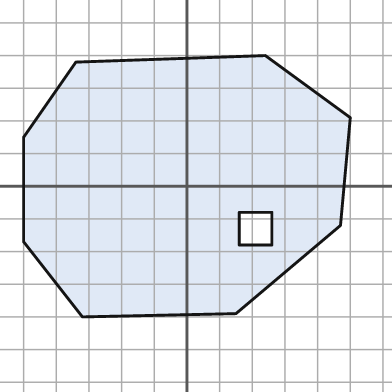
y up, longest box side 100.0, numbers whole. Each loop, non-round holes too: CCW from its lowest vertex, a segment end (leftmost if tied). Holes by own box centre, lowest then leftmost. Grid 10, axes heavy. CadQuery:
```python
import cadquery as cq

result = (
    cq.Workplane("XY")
    .moveTo(-32.0, -40.0)
    .lineTo(15.0, -39.0)
    .lineTo(47.0, -12.0)
    .lineTo(50.0, 21.0)
    .lineTo(24.0, 40.0)
    .lineTo(-34.0, 38.0)
    .lineTo(-50.0, 15.0)
    .lineTo(-50.0, -17.0)
    .close()
    .moveTo(16.0, -18.0)
    .lineTo(26.0, -18.0)
    .lineTo(26.0, -8.0)
    .lineTo(16.0, -8.0)
    .close()
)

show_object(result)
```